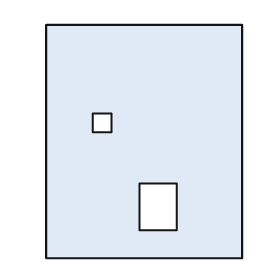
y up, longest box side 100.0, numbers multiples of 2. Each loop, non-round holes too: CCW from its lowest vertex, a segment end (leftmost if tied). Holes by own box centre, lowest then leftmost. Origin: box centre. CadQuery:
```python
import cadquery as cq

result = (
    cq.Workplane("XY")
    .moveTo(-42.0, -50.0)
    .lineTo(42.0, -50.0)
    .lineTo(42.0, 50.0)
    .lineTo(-42.0, 50.0)
    .close()
    .moveTo(-2.0, -38.0)
    .lineTo(14.0, -38.0)
    .lineTo(14.0, -18.0)
    .lineTo(-2.0, -18.0)
    .close()
    .moveTo(-22.0, 4.0)
    .lineTo(-14.0, 4.0)
    .lineTo(-14.0, 12.0)
    .lineTo(-22.0, 12.0)
    .close()
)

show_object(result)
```